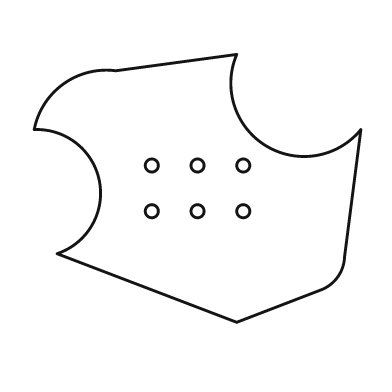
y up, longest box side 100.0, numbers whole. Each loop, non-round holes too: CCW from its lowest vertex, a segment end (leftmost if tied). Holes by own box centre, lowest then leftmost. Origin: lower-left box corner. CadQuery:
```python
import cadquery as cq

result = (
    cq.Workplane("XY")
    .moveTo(62.0, 0.0)
    .lineTo(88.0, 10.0)
    .threePointArc((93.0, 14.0), (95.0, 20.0))
    .lineTo(100.0, 59.0)
    .threePointArc((71.0, 54.0), (62.0, 82.0))
    .lineTo(25.0, 77.0)
    .threePointArc((9.0, 73.0), (0.0, 59.0))
    .threePointArc((20.0, 43.0), (7.0, 21.0))
    .close()
    .moveTo(36.0, 34.0)
    .circle(2.0)
    .moveTo(50.0, 34.0)
    .circle(2.0)
    .moveTo(64.0, 34.0)
    .circle(2.0)
    .moveTo(36.0, 48.0)
    .circle(2.0)
    .moveTo(50.0, 48.0)
    .circle(2.0)
    .moveTo(64.0, 48.0)
    .circle(2.0)
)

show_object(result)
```